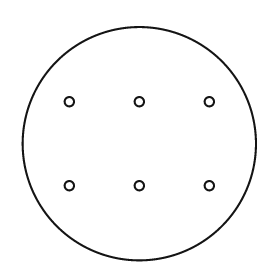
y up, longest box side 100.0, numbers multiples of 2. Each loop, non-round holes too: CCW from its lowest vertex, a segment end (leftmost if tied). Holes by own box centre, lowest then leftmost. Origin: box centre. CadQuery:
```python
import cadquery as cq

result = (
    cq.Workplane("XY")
    .moveTo(0.0, 0.0)
    .circle(50.0)
    .moveTo(-30.0, -18.0)
    .circle(2.0)
    .moveTo(0.0, -18.0)
    .circle(2.0)
    .moveTo(30.0, -18.0)
    .circle(2.0)
    .moveTo(-30.0, 18.0)
    .circle(2.0)
    .moveTo(0.0, 18.0)
    .circle(2.0)
    .moveTo(30.0, 18.0)
    .circle(2.0)
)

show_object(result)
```